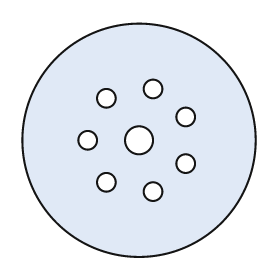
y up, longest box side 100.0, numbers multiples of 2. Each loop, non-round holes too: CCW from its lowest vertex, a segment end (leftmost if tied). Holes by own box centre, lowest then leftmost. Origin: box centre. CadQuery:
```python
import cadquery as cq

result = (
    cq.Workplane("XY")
    .moveTo(0.0, 0.0)
    .circle(50.0)
    .moveTo(6.0, -22.0)
    .circle(4.0)
    .moveTo(-14.0, -18.0)
    .circle(4.0)
    .moveTo(20.0, -10.0)
    .circle(4.0)
    .moveTo(-22.0, 0.0)
    .circle(4.0)
    .moveTo(0.0, 0.0)
    .circle(6.0)
    .moveTo(20.0, 10.0)
    .circle(4.0)
    .moveTo(-14.0, 18.0)
    .circle(4.0)
    .moveTo(6.0, 22.0)
    .circle(4.0)
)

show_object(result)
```